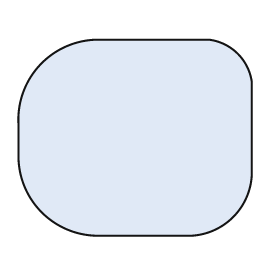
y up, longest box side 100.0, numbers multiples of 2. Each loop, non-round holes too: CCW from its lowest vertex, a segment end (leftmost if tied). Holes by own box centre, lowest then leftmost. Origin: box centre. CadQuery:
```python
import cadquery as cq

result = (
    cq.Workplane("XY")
    .moveTo(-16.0, -42.0)
    .lineTo(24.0, -42.0)
    .threePointArc((42.0, -34.0), (50.0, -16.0))
    .lineTo(50.0, 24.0)
    .threePointArc((44.0, 36.0), (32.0, 42.0))
    .lineTo(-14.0, 42.0)
    .threePointArc((-40.0, 32.0), (-50.0, 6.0))
    .lineTo(-50.0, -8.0)
    .threePointArc((-40.0, -32.0), (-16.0, -42.0))
    .close()
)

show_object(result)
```